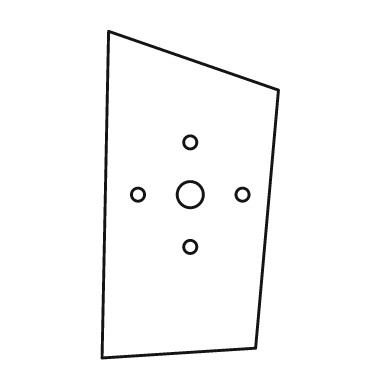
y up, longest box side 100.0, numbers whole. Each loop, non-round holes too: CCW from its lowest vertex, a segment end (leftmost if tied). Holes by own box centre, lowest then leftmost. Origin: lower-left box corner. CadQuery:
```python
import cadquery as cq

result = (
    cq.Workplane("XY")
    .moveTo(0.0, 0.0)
    .lineTo(47.0, 3.0)
    .lineTo(54.0, 82.0)
    .lineTo(2.0, 100.0)
    .close()
    .moveTo(27.0, 34.0)
    .circle(2.0)
    .moveTo(11.0, 50.0)
    .circle(2.0)
    .moveTo(27.0, 50.0)
    .circle(4.0)
    .moveTo(43.0, 50.0)
    .circle(2.0)
    .moveTo(27.0, 66.0)
    .circle(2.0)
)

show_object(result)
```